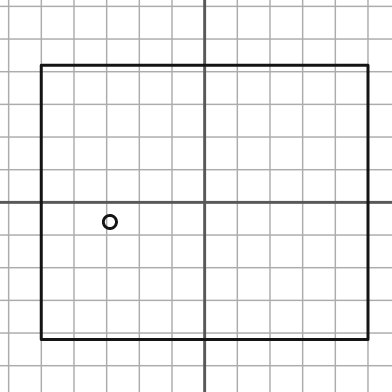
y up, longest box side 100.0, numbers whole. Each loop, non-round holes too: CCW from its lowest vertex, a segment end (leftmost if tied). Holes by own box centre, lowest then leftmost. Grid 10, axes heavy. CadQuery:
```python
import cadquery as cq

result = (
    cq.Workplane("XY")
    .moveTo(-50.0, -42.0)
    .lineTo(50.0, -42.0)
    .lineTo(50.0, 42.0)
    .lineTo(-50.0, 42.0)
    .close()
    .moveTo(-29.0, -6.0)
    .circle(2.0)
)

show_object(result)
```